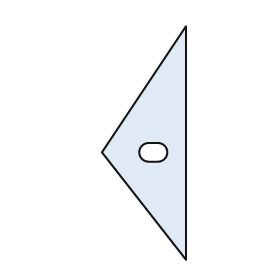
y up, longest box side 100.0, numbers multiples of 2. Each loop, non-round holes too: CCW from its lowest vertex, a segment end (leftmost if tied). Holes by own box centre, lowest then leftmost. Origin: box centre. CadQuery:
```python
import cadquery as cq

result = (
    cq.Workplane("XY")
    .moveTo(18.0, -50.0)
    .lineTo(18.0, 50.0)
    .lineTo(-18.0, -4.0)
    .close()
    .moveTo(2.0, -8.0)
    .lineTo(6.0, -8.0)
    .threePointArc((10.0, -4.0), (6.0, 0.0))
    .lineTo(2.0, 0.0)
    .threePointArc((-2.0, -4.0), (2.0, -8.0))
    .close()
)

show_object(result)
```